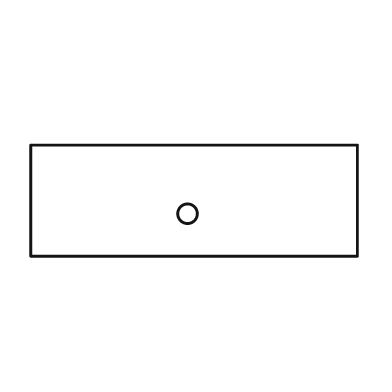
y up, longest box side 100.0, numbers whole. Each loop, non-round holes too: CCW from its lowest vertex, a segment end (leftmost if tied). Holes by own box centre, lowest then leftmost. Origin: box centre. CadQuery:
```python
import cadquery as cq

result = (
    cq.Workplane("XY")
    .moveTo(-50.0, -17.0)
    .lineTo(50.0, -17.0)
    .lineTo(50.0, 17.0)
    .lineTo(-50.0, 17.0)
    .close()
    .moveTo(-2.0, -4.0)
    .circle(3.0)
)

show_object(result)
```